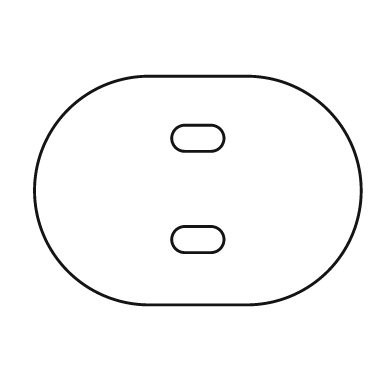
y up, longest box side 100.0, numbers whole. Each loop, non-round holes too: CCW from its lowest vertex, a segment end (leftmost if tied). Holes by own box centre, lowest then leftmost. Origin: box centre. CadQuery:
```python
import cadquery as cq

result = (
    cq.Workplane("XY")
    .moveTo(-15.0, -35.0)
    .lineTo(15.0, -35.0)
    .threePointArc((50.0, 0.0), (15.0, 35.0))
    .lineTo(-15.0, 35.0)
    .threePointArc((-50.0, 0.0), (-15.0, -35.0))
    .close()
    .moveTo(-4.0, -19.0)
    .lineTo(4.0, -19.0)
    .threePointArc((8.0, -15.0), (4.0, -11.0))
    .lineTo(-4.0, -11.0)
    .threePointArc((-8.0, -15.0), (-4.0, -19.0))
    .close()
    .moveTo(-4.0, 12.0)
    .lineTo(4.0, 12.0)
    .threePointArc((8.0, 16.0), (4.0, 20.0))
    .lineTo(-4.0, 20.0)
    .threePointArc((-8.0, 16.0), (-4.0, 12.0))
    .close()
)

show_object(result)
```